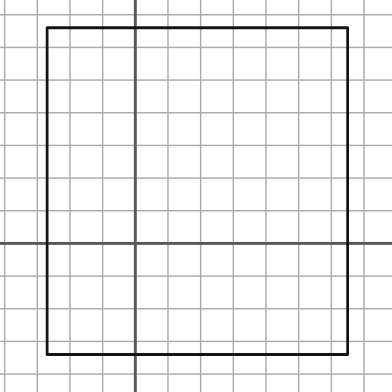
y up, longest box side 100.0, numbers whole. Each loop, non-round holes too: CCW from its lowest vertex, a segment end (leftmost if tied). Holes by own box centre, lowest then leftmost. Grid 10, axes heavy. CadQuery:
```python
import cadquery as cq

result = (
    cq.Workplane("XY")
    .moveTo(-27.0, -34.0)
    .lineTo(65.0, -34.0)
    .lineTo(65.0, 66.0)
    .lineTo(-27.0, 66.0)
    .close()
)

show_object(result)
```